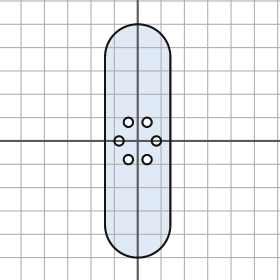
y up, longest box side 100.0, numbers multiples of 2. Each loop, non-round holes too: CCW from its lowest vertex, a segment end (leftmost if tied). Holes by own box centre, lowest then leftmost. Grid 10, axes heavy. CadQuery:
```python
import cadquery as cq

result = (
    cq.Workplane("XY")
    .moveTo(-14.0, -36.0)
    .threePointArc((0.0, -50.0), (14.0, -36.0))
    .lineTo(14.0, 36.0)
    .threePointArc((0.0, 50.0), (-14.0, 36.0))
    .close()
    .moveTo(-4.0, -8.0)
    .circle(2.0)
    .moveTo(4.0, -8.0)
    .circle(2.0)
    .moveTo(-8.0, 0.0)
    .circle(2.0)
    .moveTo(8.0, 0.0)
    .circle(2.0)
    .moveTo(-4.0, 8.0)
    .circle(2.0)
    .moveTo(4.0, 8.0)
    .circle(2.0)
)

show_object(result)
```